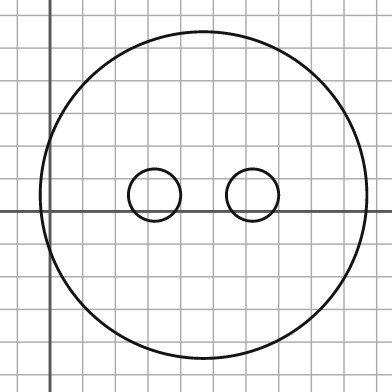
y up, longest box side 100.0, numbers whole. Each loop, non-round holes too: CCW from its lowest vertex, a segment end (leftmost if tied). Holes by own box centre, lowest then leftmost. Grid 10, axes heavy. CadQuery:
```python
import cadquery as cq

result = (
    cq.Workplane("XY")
    .moveTo(47.0, 5.0)
    .circle(50.0)
    .moveTo(32.0, 5.0)
    .circle(8.0)
    .moveTo(62.0, 5.0)
    .circle(8.0)
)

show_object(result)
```